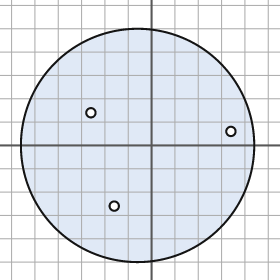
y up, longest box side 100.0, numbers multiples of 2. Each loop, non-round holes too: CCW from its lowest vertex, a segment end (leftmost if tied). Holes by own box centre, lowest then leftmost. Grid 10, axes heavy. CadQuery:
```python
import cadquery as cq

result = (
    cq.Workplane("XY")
    .moveTo(-6.0, 0.0)
    .circle(50.0)
    .moveTo(-16.0, -26.0)
    .circle(2.0)
    .moveTo(34.0, 6.0)
    .circle(2.0)
    .moveTo(-26.0, 14.0)
    .circle(2.0)
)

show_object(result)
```